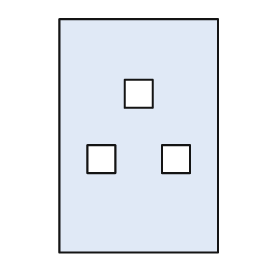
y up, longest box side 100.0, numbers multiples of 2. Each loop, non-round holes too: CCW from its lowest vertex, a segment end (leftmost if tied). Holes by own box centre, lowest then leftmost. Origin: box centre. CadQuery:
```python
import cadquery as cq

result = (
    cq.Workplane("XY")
    .moveTo(-34.0, -50.0)
    .lineTo(34.0, -50.0)
    .lineTo(34.0, 50.0)
    .lineTo(-34.0, 50.0)
    .close()
    .moveTo(-22.0, -16.0)
    .lineTo(-10.0, -16.0)
    .lineTo(-10.0, -4.0)
    .lineTo(-22.0, -4.0)
    .close()
    .moveTo(10.0, -16.0)
    .lineTo(22.0, -16.0)
    .lineTo(22.0, -4.0)
    .lineTo(10.0, -4.0)
    .close()
    .moveTo(-6.0, 12.0)
    .lineTo(6.0, 12.0)
    .lineTo(6.0, 24.0)
    .lineTo(-6.0, 24.0)
    .close()
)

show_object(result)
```